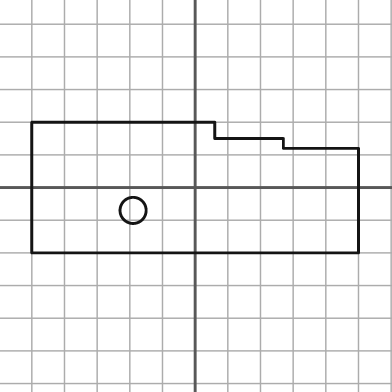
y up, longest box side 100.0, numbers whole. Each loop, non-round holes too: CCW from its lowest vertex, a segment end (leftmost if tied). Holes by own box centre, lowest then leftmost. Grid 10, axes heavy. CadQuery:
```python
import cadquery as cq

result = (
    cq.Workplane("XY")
    .moveTo(-50.0, -20.0)
    .lineTo(50.0, -20.0)
    .lineTo(50.0, 12.0)
    .lineTo(27.0, 12.0)
    .lineTo(27.0, 15.0)
    .lineTo(6.0, 15.0)
    .lineTo(6.0, 20.0)
    .lineTo(-50.0, 20.0)
    .close()
    .moveTo(-19.0, -7.0)
    .circle(4.0)
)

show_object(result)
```